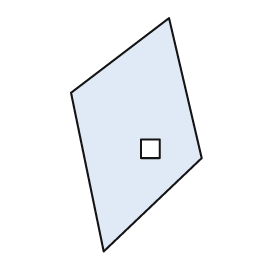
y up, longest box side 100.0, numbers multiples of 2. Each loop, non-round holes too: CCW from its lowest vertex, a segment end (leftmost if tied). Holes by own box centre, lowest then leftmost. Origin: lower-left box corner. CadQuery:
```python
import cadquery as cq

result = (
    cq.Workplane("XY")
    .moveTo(14.0, 0.0)
    .lineTo(56.0, 40.0)
    .lineTo(42.0, 100.0)
    .lineTo(0.0, 68.0)
    .close()
    .moveTo(30.0, 40.0)
    .lineTo(38.0, 40.0)
    .lineTo(38.0, 48.0)
    .lineTo(30.0, 48.0)
    .close()
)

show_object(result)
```